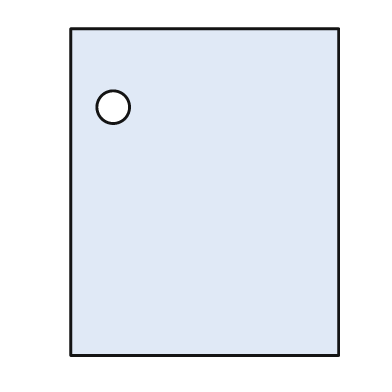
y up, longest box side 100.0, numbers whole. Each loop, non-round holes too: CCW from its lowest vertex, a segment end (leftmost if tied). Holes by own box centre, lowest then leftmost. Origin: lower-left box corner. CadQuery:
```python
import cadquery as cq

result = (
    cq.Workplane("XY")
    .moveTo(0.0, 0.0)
    .lineTo(82.0, 0.0)
    .lineTo(82.0, 100.0)
    .lineTo(0.0, 100.0)
    .close()
    .moveTo(13.0, 76.0)
    .circle(5.0)
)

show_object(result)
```